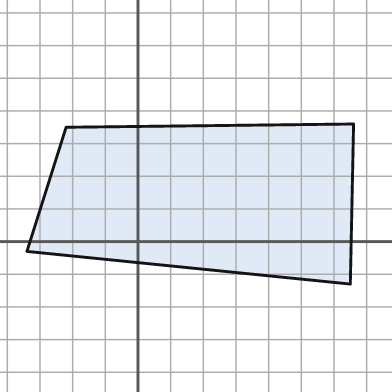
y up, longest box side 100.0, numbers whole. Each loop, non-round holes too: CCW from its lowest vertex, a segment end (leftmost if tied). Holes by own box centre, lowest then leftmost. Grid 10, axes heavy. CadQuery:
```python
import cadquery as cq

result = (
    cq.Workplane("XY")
    .moveTo(65.0, -13.0)
    .lineTo(66.0, 36.0)
    .lineTo(-22.0, 35.0)
    .lineTo(-34.0, -3.0)
    .close()
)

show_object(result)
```